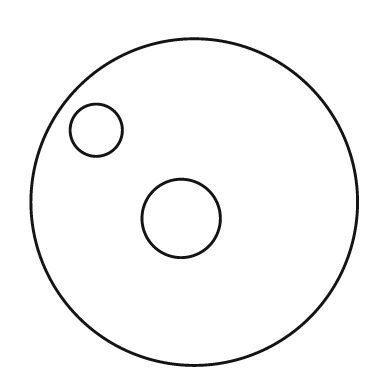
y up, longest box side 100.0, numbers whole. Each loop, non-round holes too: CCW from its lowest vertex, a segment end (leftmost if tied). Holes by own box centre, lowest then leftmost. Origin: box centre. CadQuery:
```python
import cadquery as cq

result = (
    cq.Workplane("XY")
    .moveTo(0.0, 0.0)
    .circle(50.0)
    .moveTo(-4.0, -5.0)
    .circle(12.0)
    .moveTo(-30.0, 22.0)
    .circle(8.0)
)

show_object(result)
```